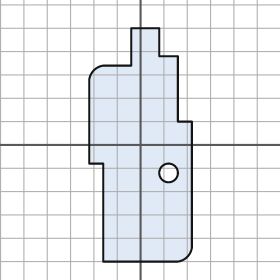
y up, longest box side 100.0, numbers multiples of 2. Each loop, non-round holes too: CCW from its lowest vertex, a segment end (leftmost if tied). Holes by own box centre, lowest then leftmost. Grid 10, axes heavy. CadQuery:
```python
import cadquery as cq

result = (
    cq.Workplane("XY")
    .moveTo(-16.0, -50.0)
    .lineTo(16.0, -50.0)
    .threePointArc((20.0, -48.0), (22.0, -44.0))
    .lineTo(22.0, 10.0)
    .lineTo(16.0, 10.0)
    .lineTo(16.0, 38.0)
    .lineTo(8.0, 38.0)
    .lineTo(8.0, 50.0)
    .lineTo(-4.0, 50.0)
    .lineTo(-4.0, 34.0)
    .lineTo(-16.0, 34.0)
    .threePointArc((-20.0, 32.0), (-22.0, 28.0))
    .lineTo(-22.0, -8.0)
    .lineTo(-16.0, -8.0)
    .close()
    .moveTo(12.0, -12.0)
    .circle(4.0)
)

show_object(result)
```